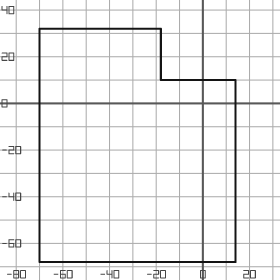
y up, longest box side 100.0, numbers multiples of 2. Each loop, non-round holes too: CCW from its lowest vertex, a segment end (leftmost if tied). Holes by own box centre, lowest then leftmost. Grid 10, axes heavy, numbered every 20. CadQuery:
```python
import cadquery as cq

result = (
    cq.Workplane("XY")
    .moveTo(-70.0, -68.0)
    .lineTo(14.0, -68.0)
    .lineTo(14.0, 10.0)
    .lineTo(-18.0, 10.0)
    .lineTo(-18.0, 32.0)
    .lineTo(-70.0, 32.0)
    .close()
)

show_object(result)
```